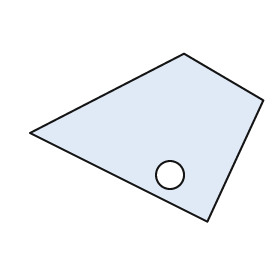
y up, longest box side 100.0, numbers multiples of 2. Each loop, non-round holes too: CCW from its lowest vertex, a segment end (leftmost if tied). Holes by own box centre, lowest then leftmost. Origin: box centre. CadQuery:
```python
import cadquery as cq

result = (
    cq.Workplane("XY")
    .moveTo(26.0, -36.0)
    .lineTo(50.0, 16.0)
    .lineTo(16.0, 36.0)
    .lineTo(-50.0, 2.0)
    .close()
    .moveTo(10.0, -16.0)
    .circle(6.0)
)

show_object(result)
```